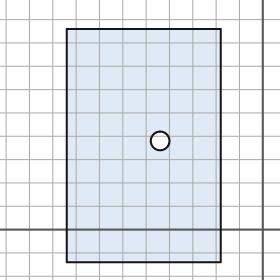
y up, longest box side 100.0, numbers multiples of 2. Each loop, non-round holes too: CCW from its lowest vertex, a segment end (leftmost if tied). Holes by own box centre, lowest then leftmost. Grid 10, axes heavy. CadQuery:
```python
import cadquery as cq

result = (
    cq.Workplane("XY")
    .moveTo(-84.0, -14.0)
    .lineTo(-18.0, -14.0)
    .lineTo(-18.0, 86.0)
    .lineTo(-84.0, 86.0)
    .close()
    .moveTo(-44.0, 38.0)
    .circle(4.0)
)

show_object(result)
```